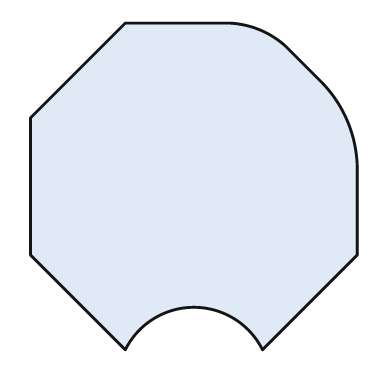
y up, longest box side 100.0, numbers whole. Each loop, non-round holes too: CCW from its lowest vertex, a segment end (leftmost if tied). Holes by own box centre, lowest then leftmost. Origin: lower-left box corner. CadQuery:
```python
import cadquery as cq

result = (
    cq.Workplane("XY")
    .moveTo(29.0, 0.0)
    .threePointArc((50.0, 13.0), (71.0, 0.0))
    .lineTo(100.0, 29.0)
    .lineTo(100.0, 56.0)
    .threePointArc((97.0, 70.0), (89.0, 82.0))
    .lineTo(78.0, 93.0)
    .threePointArc((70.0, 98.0), (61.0, 100.0))
    .lineTo(29.0, 100.0)
    .lineTo(0.0, 71.0)
    .lineTo(0.0, 29.0)
    .close()
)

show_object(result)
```